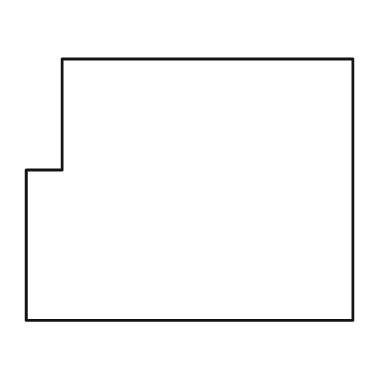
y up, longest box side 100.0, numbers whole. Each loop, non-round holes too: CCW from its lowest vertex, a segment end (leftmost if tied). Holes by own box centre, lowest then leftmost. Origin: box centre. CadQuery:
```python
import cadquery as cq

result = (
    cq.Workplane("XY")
    .moveTo(-50.0, -40.0)
    .lineTo(50.0, -40.0)
    .lineTo(50.0, 40.0)
    .lineTo(-39.0, 40.0)
    .lineTo(-39.0, 6.0)
    .lineTo(-50.0, 6.0)
    .close()
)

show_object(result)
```